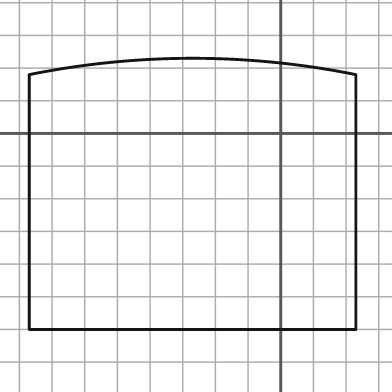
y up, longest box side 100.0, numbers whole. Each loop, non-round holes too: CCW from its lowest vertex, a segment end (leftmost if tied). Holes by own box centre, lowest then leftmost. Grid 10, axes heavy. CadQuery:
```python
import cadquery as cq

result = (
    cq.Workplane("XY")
    .moveTo(-77.0, -60.0)
    .lineTo(23.0, -60.0)
    .lineTo(23.0, 18.0)
    .threePointArc((-27.0, 23.0), (-77.0, 18.0))
    .close()
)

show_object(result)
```